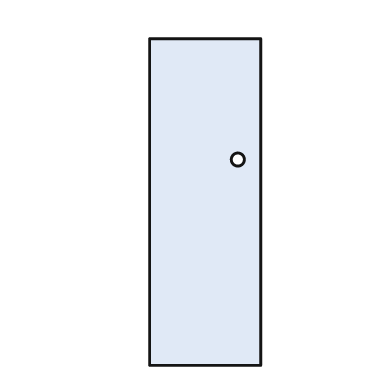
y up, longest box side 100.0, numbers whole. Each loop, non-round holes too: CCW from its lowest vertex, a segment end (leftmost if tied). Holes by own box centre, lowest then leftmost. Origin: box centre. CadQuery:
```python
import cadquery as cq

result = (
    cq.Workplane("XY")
    .moveTo(-17.0, -50.0)
    .lineTo(17.0, -50.0)
    .lineTo(17.0, 50.0)
    .lineTo(-17.0, 50.0)
    .close()
    .moveTo(10.0, 13.0)
    .circle(2.0)
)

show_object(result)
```